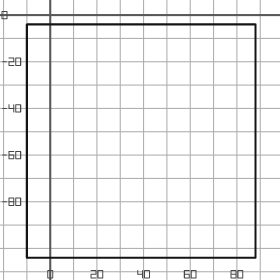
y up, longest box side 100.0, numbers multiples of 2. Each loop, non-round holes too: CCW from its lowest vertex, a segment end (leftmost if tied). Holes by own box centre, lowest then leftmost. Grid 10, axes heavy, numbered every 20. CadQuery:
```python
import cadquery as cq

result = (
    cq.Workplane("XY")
    .moveTo(-10.0, -104.0)
    .lineTo(88.0, -104.0)
    .lineTo(88.0, -4.0)
    .lineTo(-10.0, -4.0)
    .close()
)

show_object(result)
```